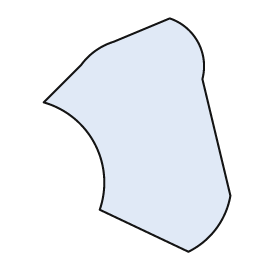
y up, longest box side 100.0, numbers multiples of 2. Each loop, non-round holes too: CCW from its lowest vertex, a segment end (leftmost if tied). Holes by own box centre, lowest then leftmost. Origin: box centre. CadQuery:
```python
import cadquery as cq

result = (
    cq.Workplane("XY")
    .moveTo(22.0, -50.0)
    .threePointArc((34.0, -40.0), (40.0, -26.0))
    .lineTo(28.0, 24.0)
    .threePointArc((26.0, 40.0), (14.0, 50.0))
    .lineTo(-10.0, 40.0)
    .threePointArc((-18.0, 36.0), (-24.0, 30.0))
    .lineTo(-40.0, 14.0)
    .threePointArc((-18.0, -4.0), (-16.0, -32.0))
    .close()
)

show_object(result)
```